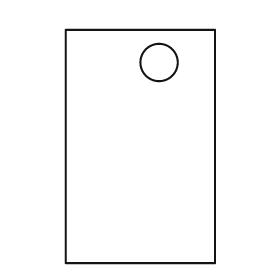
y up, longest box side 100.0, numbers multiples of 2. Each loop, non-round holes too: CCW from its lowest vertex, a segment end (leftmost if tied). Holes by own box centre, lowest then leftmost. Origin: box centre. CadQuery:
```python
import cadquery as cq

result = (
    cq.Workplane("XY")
    .moveTo(-32.0, -50.0)
    .lineTo(32.0, -50.0)
    .lineTo(32.0, 50.0)
    .lineTo(-32.0, 50.0)
    .close()
    .moveTo(8.0, 36.0)
    .circle(8.0)
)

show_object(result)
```